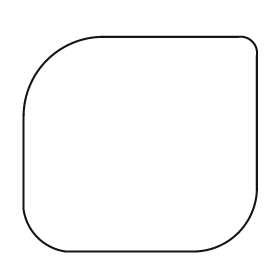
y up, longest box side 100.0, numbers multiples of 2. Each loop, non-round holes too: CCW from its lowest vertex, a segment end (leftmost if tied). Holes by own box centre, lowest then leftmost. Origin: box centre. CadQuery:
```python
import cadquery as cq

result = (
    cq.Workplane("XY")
    .moveTo(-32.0, -46.0)
    .lineTo(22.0, -46.0)
    .threePointArc((42.0, -38.0), (50.0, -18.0))
    .lineTo(50.0, 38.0)
    .threePointArc((48.0, 44.0), (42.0, 46.0))
    .lineTo(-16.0, 46.0)
    .threePointArc((-40.0, 36.0), (-50.0, 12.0))
    .lineTo(-50.0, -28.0)
    .threePointArc((-44.0, -40.0), (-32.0, -46.0))
    .close()
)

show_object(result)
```